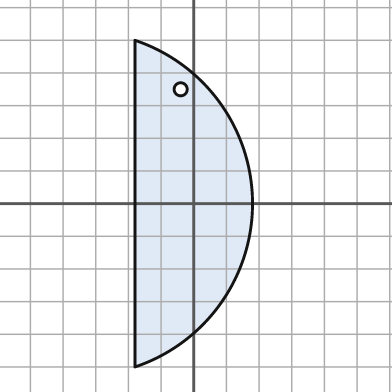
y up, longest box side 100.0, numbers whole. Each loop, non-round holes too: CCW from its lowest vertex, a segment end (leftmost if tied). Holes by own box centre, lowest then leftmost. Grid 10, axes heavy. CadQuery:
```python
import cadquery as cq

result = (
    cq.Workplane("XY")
    .moveTo(-18.0, -50.0)
    .threePointArc((18.0, 0.0), (-18.0, 50.0))
    .close()
    .moveTo(-4.0, 35.0)
    .circle(2.0)
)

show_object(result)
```